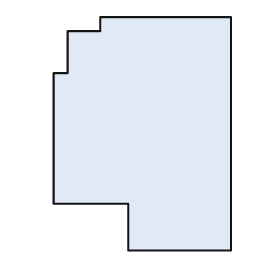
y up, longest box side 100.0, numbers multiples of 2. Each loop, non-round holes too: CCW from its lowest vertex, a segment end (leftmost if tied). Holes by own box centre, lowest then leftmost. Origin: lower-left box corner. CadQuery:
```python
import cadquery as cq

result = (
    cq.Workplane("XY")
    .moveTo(32.0, 0.0)
    .lineTo(76.0, 0.0)
    .lineTo(76.0, 100.0)
    .lineTo(20.0, 100.0)
    .lineTo(20.0, 94.0)
    .lineTo(6.0, 94.0)
    .lineTo(6.0, 76.0)
    .lineTo(0.0, 76.0)
    .lineTo(0.0, 20.0)
    .lineTo(32.0, 20.0)
    .close()
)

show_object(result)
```